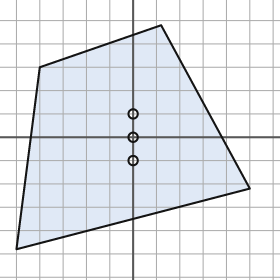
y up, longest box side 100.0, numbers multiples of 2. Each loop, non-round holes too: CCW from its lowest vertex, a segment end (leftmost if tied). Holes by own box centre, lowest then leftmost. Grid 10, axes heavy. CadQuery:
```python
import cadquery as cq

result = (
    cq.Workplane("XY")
    .moveTo(-50.0, -48.0)
    .lineTo(50.0, -22.0)
    .lineTo(12.0, 48.0)
    .lineTo(-40.0, 30.0)
    .close()
    .moveTo(0.0, -10.0)
    .circle(2.0)
    .moveTo(0.0, 0.0)
    .circle(2.0)
    .moveTo(0.0, 10.0)
    .circle(2.0)
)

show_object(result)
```